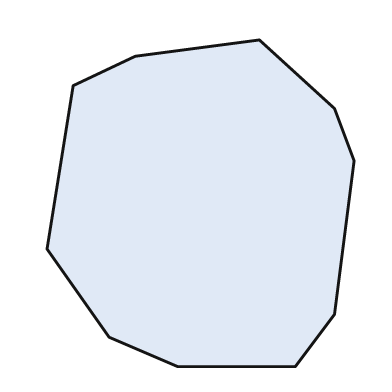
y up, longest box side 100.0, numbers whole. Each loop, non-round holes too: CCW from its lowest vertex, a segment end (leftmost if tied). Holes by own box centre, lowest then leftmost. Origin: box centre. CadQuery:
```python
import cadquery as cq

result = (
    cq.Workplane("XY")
    .moveTo(-7.0, -50.0)
    .lineTo(29.0, -50.0)
    .lineTo(41.0, -34.0)
    .lineTo(47.0, 13.0)
    .lineTo(41.0, 29.0)
    .lineTo(18.0, 50.0)
    .lineTo(-20.0, 45.0)
    .lineTo(-39.0, 36.0)
    .lineTo(-47.0, -14.0)
    .lineTo(-28.0, -41.0)
    .close()
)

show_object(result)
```